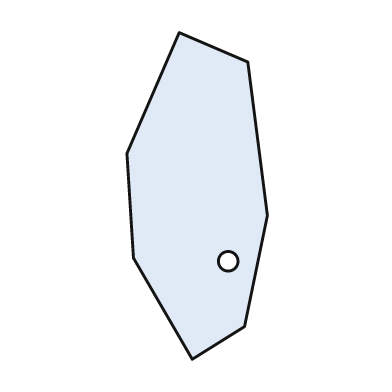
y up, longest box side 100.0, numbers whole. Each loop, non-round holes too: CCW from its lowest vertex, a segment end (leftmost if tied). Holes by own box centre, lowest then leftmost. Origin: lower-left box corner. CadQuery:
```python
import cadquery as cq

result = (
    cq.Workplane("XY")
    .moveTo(20.0, 0.0)
    .lineTo(36.0, 10.0)
    .lineTo(43.0, 44.0)
    .lineTo(37.0, 91.0)
    .lineTo(16.0, 100.0)
    .lineTo(0.0, 63.0)
    .lineTo(2.0, 31.0)
    .close()
    .moveTo(31.0, 30.0)
    .circle(3.0)
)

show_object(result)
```